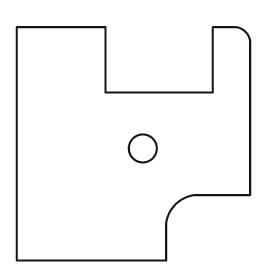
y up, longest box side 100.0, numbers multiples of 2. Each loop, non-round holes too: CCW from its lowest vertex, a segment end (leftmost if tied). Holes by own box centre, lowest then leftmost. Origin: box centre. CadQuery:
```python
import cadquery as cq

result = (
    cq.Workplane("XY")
    .moveTo(-50.0, -50.0)
    .lineTo(14.0, -50.0)
    .lineTo(14.0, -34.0)
    .threePointArc((18.0, -26.0), (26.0, -22.0))
    .lineTo(50.0, -22.0)
    .lineTo(50.0, 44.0)
    .threePointArc((48.0, 48.0), (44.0, 50.0))
    .lineTo(34.0, 50.0)
    .lineTo(34.0, 22.0)
    .lineTo(-12.0, 22.0)
    .lineTo(-12.0, 50.0)
    .lineTo(-50.0, 50.0)
    .close()
    .moveTo(4.0, -2.0)
    .circle(6.0)
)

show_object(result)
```